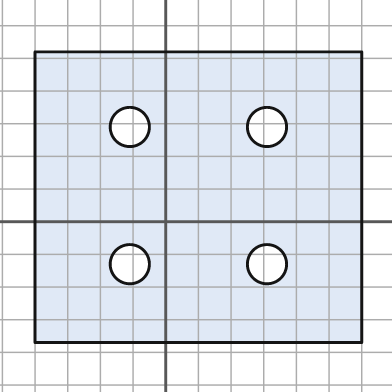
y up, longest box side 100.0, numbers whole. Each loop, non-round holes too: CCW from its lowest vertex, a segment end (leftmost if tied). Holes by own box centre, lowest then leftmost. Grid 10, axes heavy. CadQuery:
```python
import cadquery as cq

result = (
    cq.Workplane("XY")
    .moveTo(-40.0, -37.0)
    .lineTo(60.0, -37.0)
    .lineTo(60.0, 52.0)
    .lineTo(-40.0, 52.0)
    .close()
    .moveTo(-11.0, -13.0)
    .circle(6.0)
    .moveTo(31.0, -13.0)
    .circle(6.0)
    .moveTo(-11.0, 29.0)
    .circle(6.0)
    .moveTo(31.0, 29.0)
    .circle(6.0)
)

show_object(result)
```